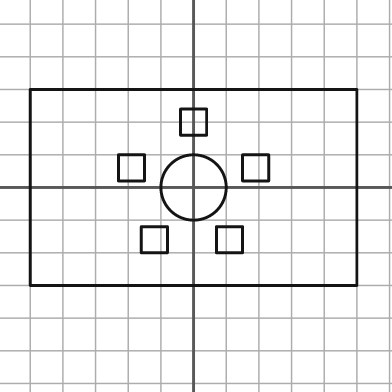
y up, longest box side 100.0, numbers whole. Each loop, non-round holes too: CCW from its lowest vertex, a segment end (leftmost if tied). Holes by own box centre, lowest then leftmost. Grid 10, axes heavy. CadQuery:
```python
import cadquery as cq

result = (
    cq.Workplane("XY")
    .moveTo(-50.0, -30.0)
    .lineTo(50.0, -30.0)
    .lineTo(50.0, 30.0)
    .lineTo(-50.0, 30.0)
    .close()
    .moveTo(-16.0, -20.0)
    .lineTo(-8.0, -20.0)
    .lineTo(-8.0, -12.0)
    .lineTo(-16.0, -12.0)
    .close()
    .moveTo(7.0, -20.0)
    .lineTo(15.0, -20.0)
    .lineTo(15.0, -12.0)
    .lineTo(7.0, -12.0)
    .close()
    .moveTo(0.0, 0.0)
    .circle(10.0)
    .moveTo(-23.0, 2.0)
    .lineTo(-15.0, 2.0)
    .lineTo(-15.0, 10.0)
    .lineTo(-23.0, 10.0)
    .close()
    .moveTo(15.0, 2.0)
    .lineTo(23.0, 2.0)
    .lineTo(23.0, 10.0)
    .lineTo(15.0, 10.0)
    .close()
    .moveTo(-4.0, 16.0)
    .lineTo(4.0, 16.0)
    .lineTo(4.0, 24.0)
    .lineTo(-4.0, 24.0)
    .close()
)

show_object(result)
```